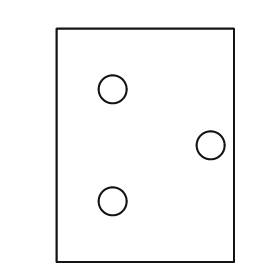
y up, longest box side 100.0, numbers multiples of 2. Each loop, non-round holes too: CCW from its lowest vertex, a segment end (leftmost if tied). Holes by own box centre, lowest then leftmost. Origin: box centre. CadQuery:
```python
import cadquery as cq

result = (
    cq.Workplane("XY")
    .moveTo(-38.0, -50.0)
    .lineTo(38.0, -50.0)
    .lineTo(38.0, 50.0)
    .lineTo(-38.0, 50.0)
    .close()
    .moveTo(-14.0, -24.0)
    .circle(6.0)
    .moveTo(28.0, 0.0)
    .circle(6.0)
    .moveTo(-14.0, 24.0)
    .circle(6.0)
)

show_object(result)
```